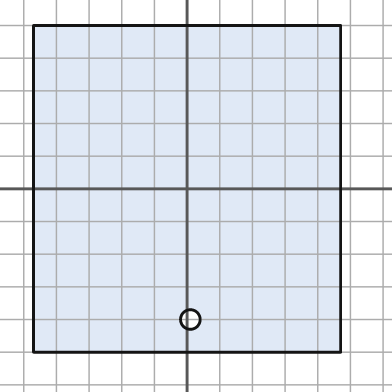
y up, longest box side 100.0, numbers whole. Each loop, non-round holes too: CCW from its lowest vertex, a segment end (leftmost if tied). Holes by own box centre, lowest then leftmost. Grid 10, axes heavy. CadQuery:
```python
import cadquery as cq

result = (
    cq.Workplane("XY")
    .moveTo(-47.0, -50.0)
    .lineTo(47.0, -50.0)
    .lineTo(47.0, 50.0)
    .lineTo(-47.0, 50.0)
    .close()
    .moveTo(1.0, -40.0)
    .circle(3.0)
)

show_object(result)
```